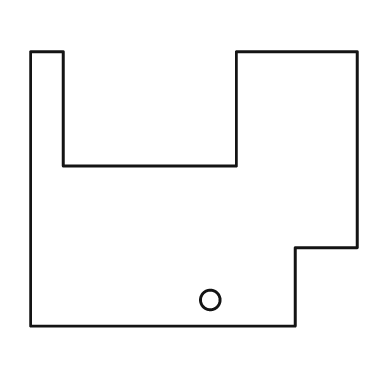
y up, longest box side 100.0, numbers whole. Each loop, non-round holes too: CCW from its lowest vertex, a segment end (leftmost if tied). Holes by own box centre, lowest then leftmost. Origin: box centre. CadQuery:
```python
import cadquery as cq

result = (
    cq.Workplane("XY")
    .moveTo(-50.0, -42.0)
    .lineTo(31.0, -42.0)
    .lineTo(31.0, -18.0)
    .lineTo(50.0, -18.0)
    .lineTo(50.0, 42.0)
    .lineTo(13.0, 42.0)
    .lineTo(13.0, 7.0)
    .lineTo(-40.0, 7.0)
    .lineTo(-40.0, 42.0)
    .lineTo(-50.0, 42.0)
    .close()
    .moveTo(5.0, -34.0)
    .circle(3.0)
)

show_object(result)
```